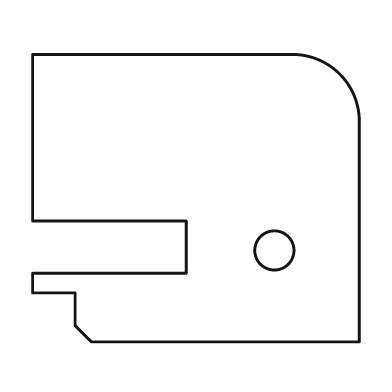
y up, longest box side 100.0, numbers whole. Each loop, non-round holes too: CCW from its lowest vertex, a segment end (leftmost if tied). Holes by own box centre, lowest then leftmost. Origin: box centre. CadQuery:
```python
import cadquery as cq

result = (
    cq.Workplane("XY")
    .moveTo(-32.0, -44.0)
    .lineTo(50.0, -44.0)
    .lineTo(50.0, 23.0)
    .threePointArc((44.0, 38.0), (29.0, 44.0))
    .lineTo(-50.0, 44.0)
    .lineTo(-50.0, -7.0)
    .lineTo(-3.0, -7.0)
    .lineTo(-3.0, -23.0)
    .lineTo(-50.0, -23.0)
    .lineTo(-50.0, -29.0)
    .lineTo(-37.0, -29.0)
    .lineTo(-37.0, -39.0)
    .close()
    .moveTo(24.0, -16.0)
    .circle(6.0)
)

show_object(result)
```